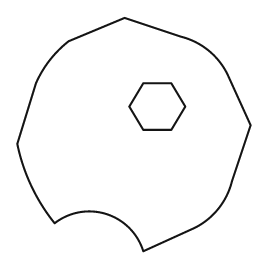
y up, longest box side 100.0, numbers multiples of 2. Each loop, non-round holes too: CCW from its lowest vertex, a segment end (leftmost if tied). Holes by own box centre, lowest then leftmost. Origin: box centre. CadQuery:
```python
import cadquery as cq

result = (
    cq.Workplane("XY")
    .moveTo(4.0, -50.0)
    .lineTo(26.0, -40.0)
    .threePointArc((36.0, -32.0), (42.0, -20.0))
    .lineTo(50.0, 4.0)
    .lineTo(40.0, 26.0)
    .threePointArc((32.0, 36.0), (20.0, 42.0))
    .lineTo(-4.0, 50.0)
    .lineTo(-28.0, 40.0)
    .threePointArc((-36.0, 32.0), (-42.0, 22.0))
    .lineTo(-50.0, -4.0)
    .threePointArc((-44.0, -22.0), (-34.0, -38.0))
    .threePointArc((-12.0, -34.0), (4.0, -50.0))
    .close()
    .moveTo(4.0, 2.0)
    .lineTo(16.0, 2.0)
    .lineTo(22.0, 12.0)
    .lineTo(16.0, 22.0)
    .lineTo(4.0, 22.0)
    .lineTo(-2.0, 12.0)
    .close()
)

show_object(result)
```